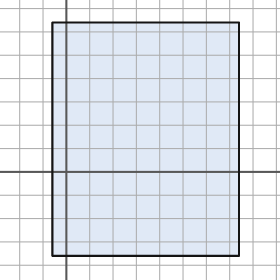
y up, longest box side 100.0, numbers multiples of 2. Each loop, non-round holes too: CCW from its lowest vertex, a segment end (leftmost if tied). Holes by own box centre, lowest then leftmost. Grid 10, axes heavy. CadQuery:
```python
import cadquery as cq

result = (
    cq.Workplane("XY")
    .moveTo(-6.0, -36.0)
    .lineTo(74.0, -36.0)
    .lineTo(74.0, 64.0)
    .lineTo(-6.0, 64.0)
    .close()
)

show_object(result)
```